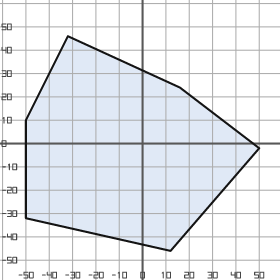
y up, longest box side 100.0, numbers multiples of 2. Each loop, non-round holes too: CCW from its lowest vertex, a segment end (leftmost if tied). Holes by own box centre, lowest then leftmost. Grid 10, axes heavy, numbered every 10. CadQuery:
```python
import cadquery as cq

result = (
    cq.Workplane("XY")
    .moveTo(12.0, -46.0)
    .lineTo(50.0, -2.0)
    .lineTo(16.0, 24.0)
    .lineTo(-32.0, 46.0)
    .lineTo(-50.0, 10.0)
    .lineTo(-50.0, -32.0)
    .close()
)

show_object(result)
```